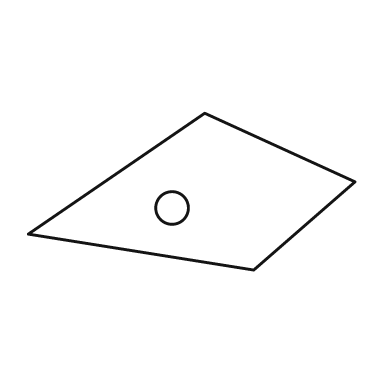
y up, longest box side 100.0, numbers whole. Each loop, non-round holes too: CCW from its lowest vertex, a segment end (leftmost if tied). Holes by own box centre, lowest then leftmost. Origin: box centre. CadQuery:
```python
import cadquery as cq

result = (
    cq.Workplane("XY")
    .moveTo(19.0, -24.0)
    .lineTo(50.0, 3.0)
    .lineTo(4.0, 24.0)
    .lineTo(-50.0, -13.0)
    .close()
    .moveTo(-6.0, -5.0)
    .circle(5.0)
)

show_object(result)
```